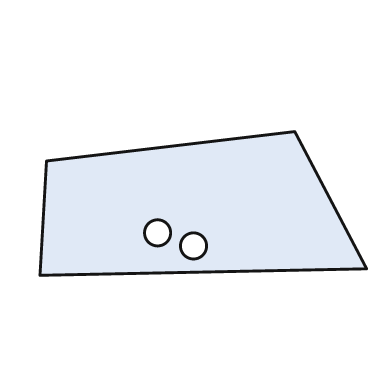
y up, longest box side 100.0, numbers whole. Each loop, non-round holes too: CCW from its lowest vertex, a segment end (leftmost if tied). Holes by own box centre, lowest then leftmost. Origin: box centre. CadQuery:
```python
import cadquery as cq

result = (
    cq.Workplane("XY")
    .moveTo(-50.0, -22.0)
    .lineTo(50.0, -20.0)
    .lineTo(28.0, 22.0)
    .lineTo(-48.0, 13.0)
    .close()
    .moveTo(-3.0, -13.0)
    .circle(4.0)
    .moveTo(-14.0, -9.0)
    .circle(4.0)
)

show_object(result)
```